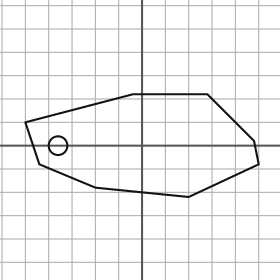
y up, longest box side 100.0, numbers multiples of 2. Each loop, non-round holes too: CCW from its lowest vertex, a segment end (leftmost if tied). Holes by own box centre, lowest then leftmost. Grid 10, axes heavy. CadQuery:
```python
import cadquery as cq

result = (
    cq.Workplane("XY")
    .moveTo(20.0, -22.0)
    .lineTo(50.0, -8.0)
    .lineTo(48.0, 2.0)
    .lineTo(28.0, 22.0)
    .lineTo(-4.0, 22.0)
    .lineTo(-50.0, 10.0)
    .lineTo(-44.0, -8.0)
    .lineTo(-20.0, -18.0)
    .close()
    .moveTo(-36.0, 0.0)
    .circle(4.0)
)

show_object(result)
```